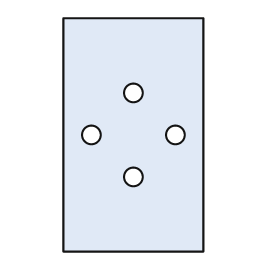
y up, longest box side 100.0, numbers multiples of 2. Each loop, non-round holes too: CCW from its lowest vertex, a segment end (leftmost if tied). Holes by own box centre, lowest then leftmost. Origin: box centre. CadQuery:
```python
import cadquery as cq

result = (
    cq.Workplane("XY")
    .moveTo(-30.0, -50.0)
    .lineTo(30.0, -50.0)
    .lineTo(30.0, 50.0)
    .lineTo(-30.0, 50.0)
    .close()
    .moveTo(0.0, -18.0)
    .circle(4.0)
    .moveTo(-18.0, 0.0)
    .circle(4.0)
    .moveTo(18.0, 0.0)
    .circle(4.0)
    .moveTo(0.0, 18.0)
    .circle(4.0)
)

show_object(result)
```